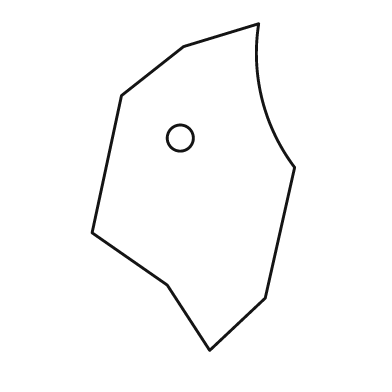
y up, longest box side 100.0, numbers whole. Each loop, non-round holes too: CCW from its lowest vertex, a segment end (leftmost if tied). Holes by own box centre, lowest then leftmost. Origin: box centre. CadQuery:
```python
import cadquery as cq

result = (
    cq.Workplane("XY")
    .moveTo(5.0, -50.0)
    .lineTo(22.0, -34.0)
    .lineTo(31.0, 6.0)
    .threePointArc((21.0, 27.0), (20.0, 50.0))
    .lineTo(-3.0, 43.0)
    .lineTo(-22.0, 28.0)
    .lineTo(-31.0, -14.0)
    .lineTo(-8.0, -30.0)
    .close()
    .moveTo(-4.0, 15.0)
    .circle(4.0)
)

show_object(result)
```